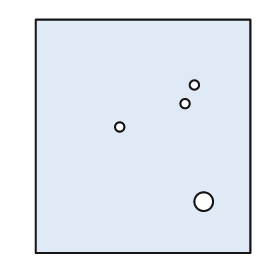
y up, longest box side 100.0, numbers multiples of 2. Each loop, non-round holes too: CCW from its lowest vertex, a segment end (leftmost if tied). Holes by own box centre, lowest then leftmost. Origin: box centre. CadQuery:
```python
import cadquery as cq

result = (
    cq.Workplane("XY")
    .moveTo(-46.0, -50.0)
    .lineTo(46.0, -50.0)
    .lineTo(46.0, 50.0)
    .lineTo(-46.0, 50.0)
    .close()
    .moveTo(26.0, -28.0)
    .circle(4.0)
    .moveTo(-10.0, 4.0)
    .circle(2.0)
    .moveTo(18.0, 14.0)
    .circle(2.0)
    .moveTo(22.0, 22.0)
    .circle(2.0)
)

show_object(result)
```